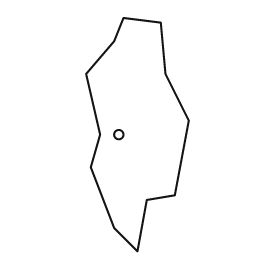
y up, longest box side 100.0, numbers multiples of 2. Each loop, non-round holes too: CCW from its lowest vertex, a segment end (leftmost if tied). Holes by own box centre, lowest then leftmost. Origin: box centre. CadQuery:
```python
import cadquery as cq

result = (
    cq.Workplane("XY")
    .moveTo(0.0, -50.0)
    .lineTo(4.0, -28.0)
    .lineTo(16.0, -26.0)
    .lineTo(22.0, 6.0)
    .lineTo(12.0, 26.0)
    .lineTo(10.0, 48.0)
    .lineTo(-6.0, 50.0)
    .lineTo(-10.0, 40.0)
    .lineTo(-22.0, 26.0)
    .lineTo(-16.0, 0.0)
    .lineTo(-20.0, -14.0)
    .lineTo(-10.0, -40.0)
    .close()
    .moveTo(-8.0, 0.0)
    .circle(2.0)
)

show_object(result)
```